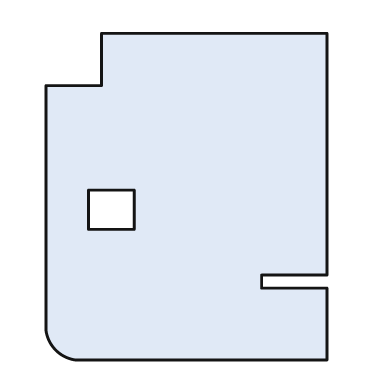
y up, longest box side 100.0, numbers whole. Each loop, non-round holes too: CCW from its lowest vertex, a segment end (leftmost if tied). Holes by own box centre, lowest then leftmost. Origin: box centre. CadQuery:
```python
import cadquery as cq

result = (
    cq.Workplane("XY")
    .moveTo(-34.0, -50.0)
    .lineTo(43.0, -50.0)
    .lineTo(43.0, -28.0)
    .lineTo(23.0, -28.0)
    .lineTo(23.0, -24.0)
    .lineTo(43.0, -24.0)
    .lineTo(43.0, 50.0)
    .lineTo(-26.0, 50.0)
    .lineTo(-26.0, 34.0)
    .lineTo(-43.0, 34.0)
    .lineTo(-43.0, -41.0)
    .threePointArc((-40.0, -47.0), (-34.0, -50.0))
    .close()
    .moveTo(-30.0, -10.0)
    .lineTo(-16.0, -10.0)
    .lineTo(-16.0, 2.0)
    .lineTo(-30.0, 2.0)
    .close()
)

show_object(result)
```